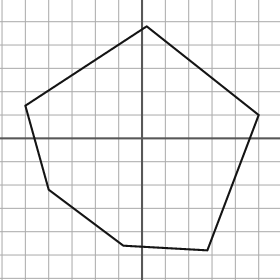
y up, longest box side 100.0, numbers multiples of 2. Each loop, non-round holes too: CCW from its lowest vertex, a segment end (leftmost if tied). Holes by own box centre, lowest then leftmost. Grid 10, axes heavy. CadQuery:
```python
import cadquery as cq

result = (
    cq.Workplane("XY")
    .moveTo(28.0, -48.0)
    .lineTo(50.0, 10.0)
    .lineTo(2.0, 48.0)
    .lineTo(-50.0, 14.0)
    .lineTo(-40.0, -22.0)
    .lineTo(-8.0, -46.0)
    .close()
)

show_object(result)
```